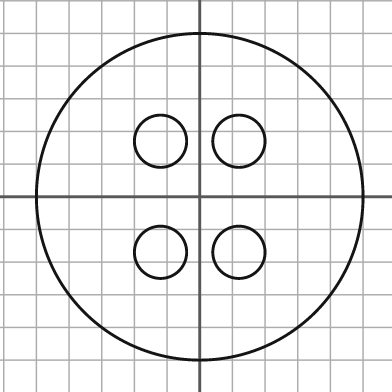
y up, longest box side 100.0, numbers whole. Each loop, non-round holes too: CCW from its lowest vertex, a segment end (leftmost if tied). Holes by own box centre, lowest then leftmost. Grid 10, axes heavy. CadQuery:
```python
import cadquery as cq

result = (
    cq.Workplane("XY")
    .moveTo(0.0, 0.0)
    .circle(50.0)
    .moveTo(-12.0, -17.0)
    .circle(8.0)
    .moveTo(12.0, -17.0)
    .circle(8.0)
    .moveTo(-12.0, 17.0)
    .circle(8.0)
    .moveTo(12.0, 17.0)
    .circle(8.0)
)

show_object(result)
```